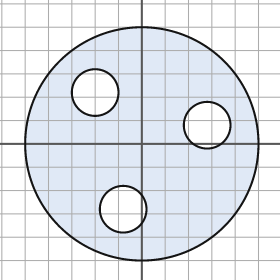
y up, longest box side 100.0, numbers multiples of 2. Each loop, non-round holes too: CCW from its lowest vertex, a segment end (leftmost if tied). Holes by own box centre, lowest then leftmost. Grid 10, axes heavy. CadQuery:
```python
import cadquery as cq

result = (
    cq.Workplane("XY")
    .moveTo(0.0, 0.0)
    .circle(50.0)
    .moveTo(-8.0, -28.0)
    .circle(10.0)
    .moveTo(28.0, 8.0)
    .circle(10.0)
    .moveTo(-20.0, 22.0)
    .circle(10.0)
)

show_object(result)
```